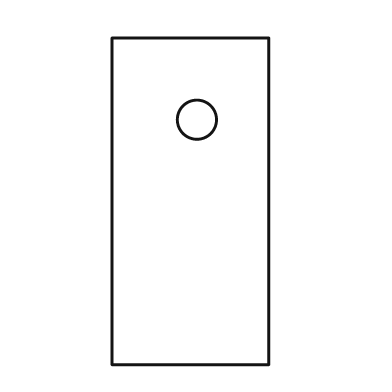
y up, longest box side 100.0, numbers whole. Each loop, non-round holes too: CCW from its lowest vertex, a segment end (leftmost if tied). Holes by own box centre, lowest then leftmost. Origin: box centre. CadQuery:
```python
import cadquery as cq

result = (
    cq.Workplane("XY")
    .moveTo(-24.0, -50.0)
    .lineTo(24.0, -50.0)
    .lineTo(24.0, 50.0)
    .lineTo(-24.0, 50.0)
    .close()
    .moveTo(2.0, 25.0)
    .circle(6.0)
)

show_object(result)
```